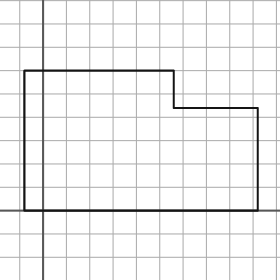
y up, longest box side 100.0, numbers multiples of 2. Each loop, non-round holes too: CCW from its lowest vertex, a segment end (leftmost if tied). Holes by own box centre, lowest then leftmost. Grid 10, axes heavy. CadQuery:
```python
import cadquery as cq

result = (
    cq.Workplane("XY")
    .moveTo(-8.0, 0.0)
    .lineTo(92.0, 0.0)
    .lineTo(92.0, 44.0)
    .lineTo(56.0, 44.0)
    .lineTo(56.0, 60.0)
    .lineTo(-8.0, 60.0)
    .close()
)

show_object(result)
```